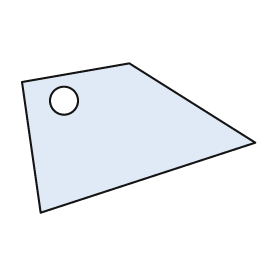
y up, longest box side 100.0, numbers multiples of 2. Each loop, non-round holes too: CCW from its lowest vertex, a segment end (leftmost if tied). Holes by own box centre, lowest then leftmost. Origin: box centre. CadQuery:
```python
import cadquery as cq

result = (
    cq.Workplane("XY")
    .moveTo(-42.0, -32.0)
    .lineTo(50.0, -2.0)
    .lineTo(-4.0, 32.0)
    .lineTo(-50.0, 24.0)
    .close()
    .moveTo(-32.0, 16.0)
    .circle(6.0)
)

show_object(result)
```